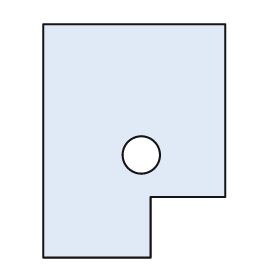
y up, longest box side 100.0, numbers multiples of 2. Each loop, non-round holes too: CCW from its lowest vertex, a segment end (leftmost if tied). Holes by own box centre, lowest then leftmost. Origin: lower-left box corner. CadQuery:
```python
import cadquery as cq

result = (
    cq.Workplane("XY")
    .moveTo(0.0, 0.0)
    .lineTo(46.0, 0.0)
    .lineTo(46.0, 26.0)
    .lineTo(78.0, 26.0)
    .lineTo(78.0, 100.0)
    .lineTo(0.0, 100.0)
    .close()
    .moveTo(42.0, 44.0)
    .circle(8.0)
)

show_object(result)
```